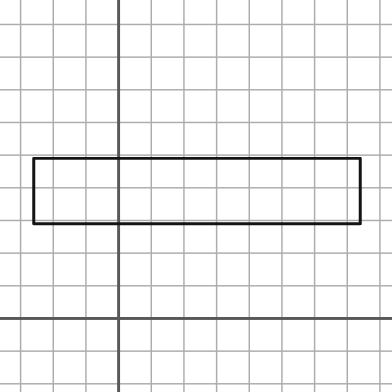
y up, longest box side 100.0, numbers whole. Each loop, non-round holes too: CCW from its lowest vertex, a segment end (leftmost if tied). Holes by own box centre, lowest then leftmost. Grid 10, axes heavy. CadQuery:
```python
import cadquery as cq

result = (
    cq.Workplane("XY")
    .moveTo(-26.0, 29.0)
    .lineTo(74.0, 29.0)
    .lineTo(74.0, 49.0)
    .lineTo(-26.0, 49.0)
    .close()
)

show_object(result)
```